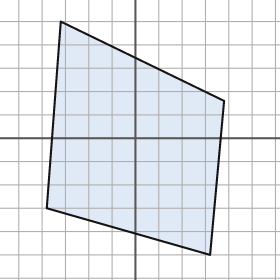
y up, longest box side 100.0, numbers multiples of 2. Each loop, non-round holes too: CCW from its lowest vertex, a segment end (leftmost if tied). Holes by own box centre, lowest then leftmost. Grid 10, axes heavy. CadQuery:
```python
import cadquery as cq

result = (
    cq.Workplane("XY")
    .moveTo(32.0, -50.0)
    .lineTo(38.0, 16.0)
    .lineTo(-32.0, 50.0)
    .lineTo(-38.0, -30.0)
    .close()
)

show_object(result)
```